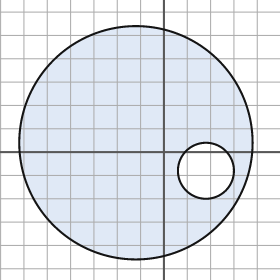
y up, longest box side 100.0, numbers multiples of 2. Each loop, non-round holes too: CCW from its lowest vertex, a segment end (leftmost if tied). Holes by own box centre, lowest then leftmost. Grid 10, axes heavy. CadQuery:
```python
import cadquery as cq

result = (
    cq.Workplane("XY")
    .moveTo(-12.0, 4.0)
    .circle(50.0)
    .moveTo(18.0, -8.0)
    .circle(12.0)
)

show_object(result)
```